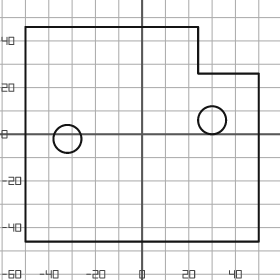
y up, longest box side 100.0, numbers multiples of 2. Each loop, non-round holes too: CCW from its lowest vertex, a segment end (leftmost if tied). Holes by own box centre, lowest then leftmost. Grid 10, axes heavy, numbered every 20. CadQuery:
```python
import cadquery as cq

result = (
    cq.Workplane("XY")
    .moveTo(-50.0, -46.0)
    .lineTo(50.0, -46.0)
    .lineTo(50.0, 26.0)
    .lineTo(24.0, 26.0)
    .lineTo(24.0, 46.0)
    .lineTo(-50.0, 46.0)
    .close()
    .moveTo(-32.0, -2.0)
    .circle(6.0)
    .moveTo(30.0, 6.0)
    .circle(6.0)
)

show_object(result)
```